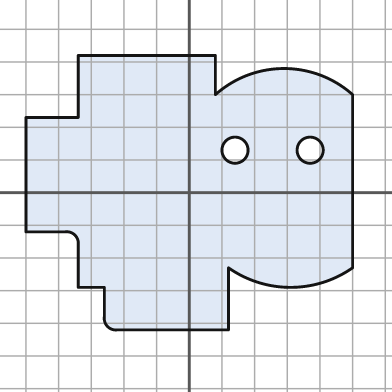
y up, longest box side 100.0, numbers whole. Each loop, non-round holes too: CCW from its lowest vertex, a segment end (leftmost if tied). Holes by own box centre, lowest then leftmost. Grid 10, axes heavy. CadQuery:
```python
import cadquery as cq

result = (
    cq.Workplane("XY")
    .moveTo(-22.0, -42.0)
    .lineTo(12.0, -42.0)
    .lineTo(12.0, -23.0)
    .threePointArc((31.0, -29.0), (50.0, -23.0))
    .lineTo(50.0, 30.0)
    .threePointArc((29.0, 38.0), (8.0, 30.0))
    .lineTo(8.0, 42.0)
    .lineTo(-34.0, 42.0)
    .lineTo(-34.0, 23.0)
    .lineTo(-50.0, 23.0)
    .lineTo(-50.0, -12.0)
    .lineTo(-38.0, -12.0)
    .threePointArc((-35.0, -13.0), (-34.0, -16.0))
    .lineTo(-34.0, -29.0)
    .lineTo(-26.0, -29.0)
    .lineTo(-26.0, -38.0)
    .threePointArc((-25.0, -41.0), (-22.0, -42.0))
    .close()
    .moveTo(14.0, 13.0)
    .circle(4.0)
    .moveTo(37.0, 13.0)
    .circle(4.0)
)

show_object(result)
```